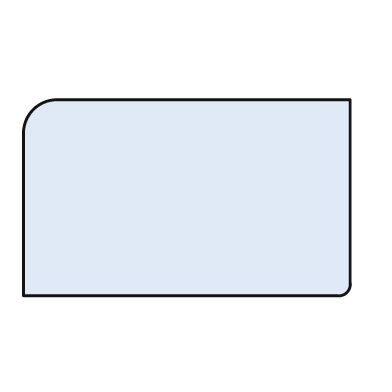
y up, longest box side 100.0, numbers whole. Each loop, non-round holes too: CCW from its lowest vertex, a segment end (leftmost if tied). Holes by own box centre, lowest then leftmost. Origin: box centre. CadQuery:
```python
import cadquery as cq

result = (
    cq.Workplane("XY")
    .moveTo(-50.0, -30.0)
    .lineTo(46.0, -30.0)
    .threePointArc((49.0, -29.0), (50.0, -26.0))
    .lineTo(50.0, 30.0)
    .lineTo(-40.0, 30.0)
    .threePointArc((-47.0, 27.0), (-50.0, 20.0))
    .close()
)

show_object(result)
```